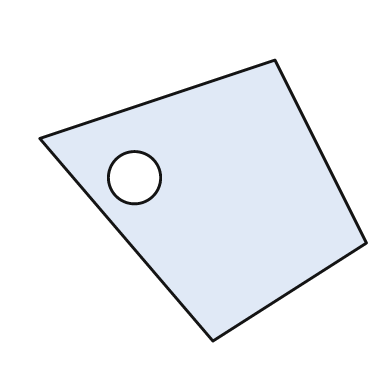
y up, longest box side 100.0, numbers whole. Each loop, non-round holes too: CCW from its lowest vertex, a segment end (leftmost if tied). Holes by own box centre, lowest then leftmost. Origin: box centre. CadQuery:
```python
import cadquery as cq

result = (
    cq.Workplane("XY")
    .moveTo(3.0, -43.0)
    .lineTo(50.0, -13.0)
    .lineTo(22.0, 43.0)
    .lineTo(-50.0, 19.0)
    .close()
    .moveTo(-21.0, 7.0)
    .circle(8.0)
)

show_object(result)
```